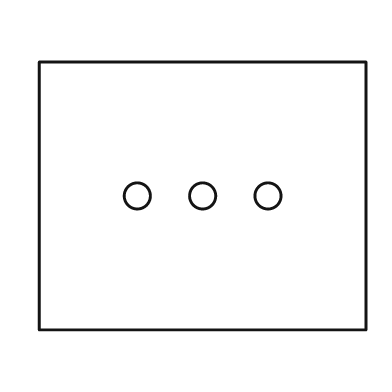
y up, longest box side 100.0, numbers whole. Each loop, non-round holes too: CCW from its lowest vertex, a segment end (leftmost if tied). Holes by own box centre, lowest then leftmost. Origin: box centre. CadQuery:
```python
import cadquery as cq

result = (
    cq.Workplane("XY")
    .moveTo(-50.0, -41.0)
    .lineTo(50.0, -41.0)
    .lineTo(50.0, 41.0)
    .lineTo(-50.0, 41.0)
    .close()
    .moveTo(-20.0, 0.0)
    .circle(4.0)
    .moveTo(0.0, 0.0)
    .circle(4.0)
    .moveTo(20.0, 0.0)
    .circle(4.0)
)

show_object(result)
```